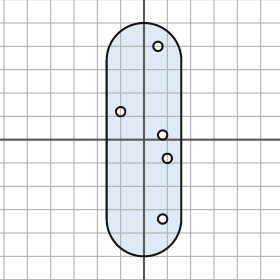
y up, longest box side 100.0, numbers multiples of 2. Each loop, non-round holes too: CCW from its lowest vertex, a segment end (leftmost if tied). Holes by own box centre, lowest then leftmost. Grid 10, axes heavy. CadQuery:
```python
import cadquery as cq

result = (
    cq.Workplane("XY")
    .moveTo(-16.0, -34.0)
    .threePointArc((0.0, -50.0), (16.0, -34.0))
    .lineTo(16.0, 34.0)
    .threePointArc((0.0, 50.0), (-16.0, 34.0))
    .close()
    .moveTo(8.0, -34.0)
    .circle(2.0)
    .moveTo(10.0, -8.0)
    .circle(2.0)
    .moveTo(8.0, 2.0)
    .circle(2.0)
    .moveTo(-10.0, 12.0)
    .circle(2.0)
    .moveTo(6.0, 40.0)
    .circle(2.0)
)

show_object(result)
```